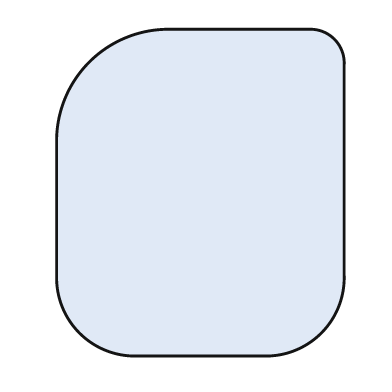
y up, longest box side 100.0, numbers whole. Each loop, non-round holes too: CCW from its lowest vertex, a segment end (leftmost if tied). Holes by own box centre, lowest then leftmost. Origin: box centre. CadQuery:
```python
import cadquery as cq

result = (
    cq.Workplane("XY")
    .moveTo(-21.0, -50.0)
    .lineTo(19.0, -50.0)
    .threePointArc((37.0, -43.0), (44.0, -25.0))
    .lineTo(44.0, 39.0)
    .threePointArc((41.0, 47.0), (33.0, 50.0))
    .lineTo(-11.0, 50.0)
    .threePointArc((-34.0, 40.0), (-44.0, 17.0))
    .lineTo(-44.0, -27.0)
    .threePointArc((-37.0, -43.0), (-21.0, -50.0))
    .close()
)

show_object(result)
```